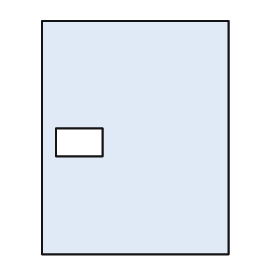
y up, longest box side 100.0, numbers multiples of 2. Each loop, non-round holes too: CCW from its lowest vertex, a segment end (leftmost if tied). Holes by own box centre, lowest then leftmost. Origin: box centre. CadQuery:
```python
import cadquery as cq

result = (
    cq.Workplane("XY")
    .moveTo(-40.0, -50.0)
    .lineTo(40.0, -50.0)
    .lineTo(40.0, 50.0)
    .lineTo(-40.0, 50.0)
    .close()
    .moveTo(-34.0, -8.0)
    .lineTo(-14.0, -8.0)
    .lineTo(-14.0, 4.0)
    .lineTo(-34.0, 4.0)
    .close()
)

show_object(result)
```